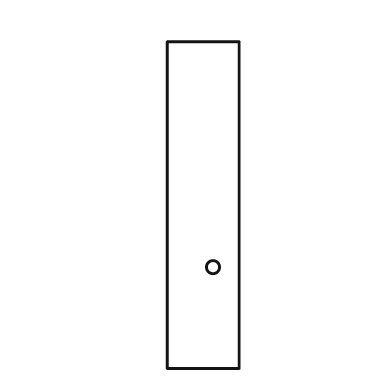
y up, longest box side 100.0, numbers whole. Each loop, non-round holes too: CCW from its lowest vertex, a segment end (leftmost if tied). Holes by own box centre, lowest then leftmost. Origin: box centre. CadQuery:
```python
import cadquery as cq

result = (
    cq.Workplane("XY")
    .moveTo(-11.0, -50.0)
    .lineTo(11.0, -50.0)
    .lineTo(11.0, 50.0)
    .lineTo(-11.0, 50.0)
    .close()
    .moveTo(3.0, -19.0)
    .circle(2.0)
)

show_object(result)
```